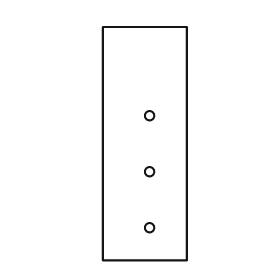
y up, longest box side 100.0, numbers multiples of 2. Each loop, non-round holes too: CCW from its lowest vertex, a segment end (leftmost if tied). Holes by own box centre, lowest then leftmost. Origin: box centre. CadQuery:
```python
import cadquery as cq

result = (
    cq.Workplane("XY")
    .moveTo(-18.0, -50.0)
    .lineTo(18.0, -50.0)
    .lineTo(18.0, 50.0)
    .lineTo(-18.0, 50.0)
    .close()
    .moveTo(2.0, -36.0)
    .circle(2.0)
    .moveTo(2.0, -12.0)
    .circle(2.0)
    .moveTo(2.0, 12.0)
    .circle(2.0)
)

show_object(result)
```